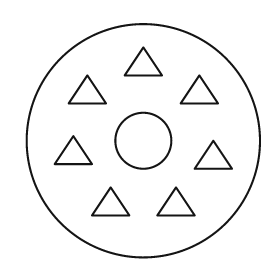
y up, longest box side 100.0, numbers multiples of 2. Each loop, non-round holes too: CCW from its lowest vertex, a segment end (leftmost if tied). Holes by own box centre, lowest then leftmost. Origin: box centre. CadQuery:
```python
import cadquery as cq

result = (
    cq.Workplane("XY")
    .moveTo(0.0, 0.0)
    .circle(50.0)
    .moveTo(-22.0, -32.0)
    .lineTo(-6.0, -32.0)
    .lineTo(-14.0, -20.0)
    .close()
    .moveTo(6.0, -32.0)
    .lineTo(22.0, -32.0)
    .lineTo(14.0, -20.0)
    .close()
    .moveTo(22.0, -12.0)
    .lineTo(38.0, -12.0)
    .lineTo(30.0, 0.0)
    .close()
    .moveTo(-38.0, -10.0)
    .lineTo(-22.0, -10.0)
    .lineTo(-30.0, 2.0)
    .close()
    .moveTo(0.0, 0.0)
    .circle(12.0)
    .moveTo(-32.0, 16.0)
    .lineTo(-16.0, 16.0)
    .lineTo(-24.0, 28.0)
    .close()
    .moveTo(16.0, 16.0)
    .lineTo(32.0, 16.0)
    .lineTo(24.0, 28.0)
    .close()
    .moveTo(-8.0, 28.0)
    .lineTo(8.0, 28.0)
    .lineTo(0.0, 40.0)
    .close()
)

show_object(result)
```